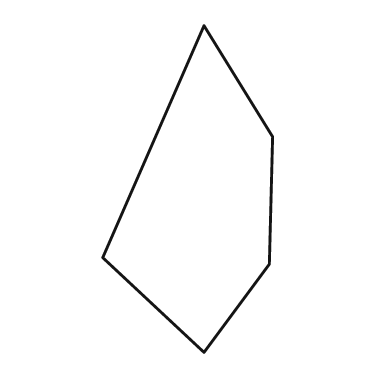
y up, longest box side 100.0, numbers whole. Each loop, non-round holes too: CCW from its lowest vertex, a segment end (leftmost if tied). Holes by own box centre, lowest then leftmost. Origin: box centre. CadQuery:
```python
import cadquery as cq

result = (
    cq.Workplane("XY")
    .moveTo(5.0, -50.0)
    .lineTo(25.0, -23.0)
    .lineTo(26.0, 16.0)
    .lineTo(5.0, 50.0)
    .lineTo(-26.0, -21.0)
    .close()
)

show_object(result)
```